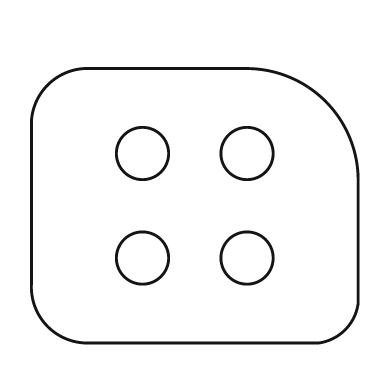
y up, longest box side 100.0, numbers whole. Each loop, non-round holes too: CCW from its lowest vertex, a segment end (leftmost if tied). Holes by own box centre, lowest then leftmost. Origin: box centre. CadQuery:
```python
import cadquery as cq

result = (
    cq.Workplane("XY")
    .moveTo(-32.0, -42.0)
    .lineTo(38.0, -42.0)
    .threePointArc((46.0, -38.0), (50.0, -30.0))
    .lineTo(50.0, 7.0)
    .threePointArc((40.0, 32.0), (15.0, 42.0))
    .lineTo(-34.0, 42.0)
    .threePointArc((-45.0, 37.0), (-50.0, 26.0))
    .lineTo(-50.0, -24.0)
    .threePointArc((-45.0, -37.0), (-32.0, -42.0))
    .close()
    .moveTo(-16.0, -16.0)
    .circle(8.0)
    .moveTo(16.0, -16.0)
    .circle(8.0)
    .moveTo(-16.0, 16.0)
    .circle(8.0)
    .moveTo(16.0, 16.0)
    .circle(8.0)
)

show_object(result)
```